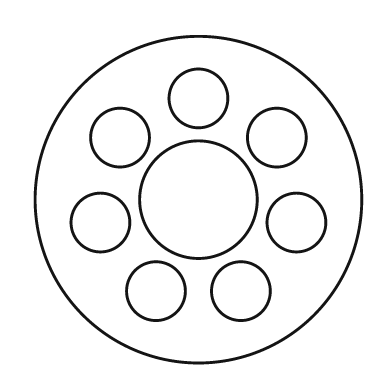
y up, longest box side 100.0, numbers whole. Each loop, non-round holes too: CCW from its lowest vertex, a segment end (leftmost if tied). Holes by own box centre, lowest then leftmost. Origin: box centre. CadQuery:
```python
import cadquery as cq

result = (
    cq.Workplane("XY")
    .moveTo(0.0, 0.0)
    .circle(50.0)
    .moveTo(-13.0, -28.0)
    .circle(9.0)
    .moveTo(13.0, -28.0)
    .circle(9.0)
    .moveTo(-30.0, -7.0)
    .circle(9.0)
    .moveTo(30.0, -7.0)
    .circle(9.0)
    .moveTo(0.0, 0.0)
    .circle(18.0)
    .moveTo(-24.0, 19.0)
    .circle(9.0)
    .moveTo(24.0, 19.0)
    .circle(9.0)
    .moveTo(0.0, 31.0)
    .circle(9.0)
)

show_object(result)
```